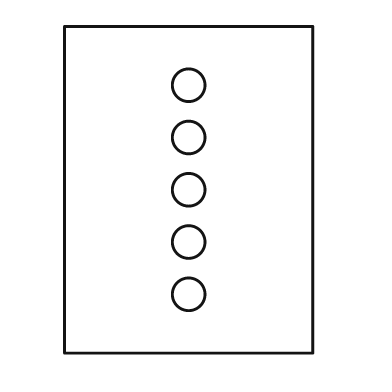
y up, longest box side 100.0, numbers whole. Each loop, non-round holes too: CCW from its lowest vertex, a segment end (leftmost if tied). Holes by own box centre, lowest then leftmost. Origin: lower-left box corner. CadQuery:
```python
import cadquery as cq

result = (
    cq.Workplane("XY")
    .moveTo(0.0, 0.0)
    .lineTo(76.0, 0.0)
    .lineTo(76.0, 100.0)
    .lineTo(0.0, 100.0)
    .close()
    .moveTo(38.0, 18.0)
    .circle(5.0)
    .moveTo(38.0, 34.0)
    .circle(5.0)
    .moveTo(38.0, 50.0)
    .circle(5.0)
    .moveTo(38.0, 66.0)
    .circle(5.0)
    .moveTo(38.0, 82.0)
    .circle(5.0)
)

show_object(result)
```